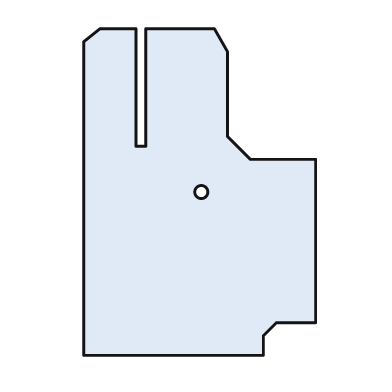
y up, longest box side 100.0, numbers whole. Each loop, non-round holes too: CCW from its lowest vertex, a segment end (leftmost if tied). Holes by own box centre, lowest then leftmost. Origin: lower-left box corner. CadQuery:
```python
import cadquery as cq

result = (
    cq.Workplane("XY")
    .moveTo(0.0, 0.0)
    .lineTo(55.0, 0.0)
    .lineTo(55.0, 6.0)
    .lineTo(59.0, 10.0)
    .lineTo(71.0, 10.0)
    .lineTo(71.0, 60.0)
    .lineTo(51.0, 60.0)
    .lineTo(44.0, 67.0)
    .lineTo(44.0, 93.0)
    .lineTo(40.0, 100.0)
    .lineTo(19.0, 100.0)
    .lineTo(19.0, 64.0)
    .lineTo(16.0, 64.0)
    .lineTo(16.0, 100.0)
    .lineTo(5.0, 100.0)
    .lineTo(0.0, 96.0)
    .close()
    .moveTo(36.0, 50.0)
    .circle(2.0)
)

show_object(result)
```